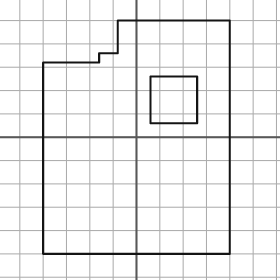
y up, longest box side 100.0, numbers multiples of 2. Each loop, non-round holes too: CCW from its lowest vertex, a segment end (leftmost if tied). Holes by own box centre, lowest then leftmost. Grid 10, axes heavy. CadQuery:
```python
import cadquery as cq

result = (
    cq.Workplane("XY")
    .moveTo(-40.0, -50.0)
    .lineTo(40.0, -50.0)
    .lineTo(40.0, 50.0)
    .lineTo(-8.0, 50.0)
    .lineTo(-8.0, 36.0)
    .lineTo(-16.0, 36.0)
    .lineTo(-16.0, 32.0)
    .lineTo(-40.0, 32.0)
    .close()
    .moveTo(6.0, 6.0)
    .lineTo(26.0, 6.0)
    .lineTo(26.0, 26.0)
    .lineTo(6.0, 26.0)
    .close()
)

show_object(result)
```